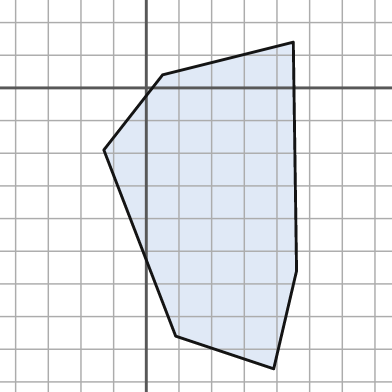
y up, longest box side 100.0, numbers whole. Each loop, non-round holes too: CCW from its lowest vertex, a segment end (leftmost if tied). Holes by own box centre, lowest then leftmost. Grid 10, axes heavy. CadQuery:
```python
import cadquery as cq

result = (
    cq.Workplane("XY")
    .moveTo(39.0, -86.0)
    .lineTo(46.0, -56.0)
    .lineTo(45.0, 14.0)
    .lineTo(5.0, 4.0)
    .lineTo(-13.0, -19.0)
    .lineTo(9.0, -76.0)
    .close()
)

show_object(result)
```